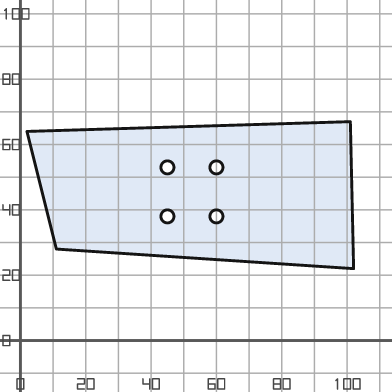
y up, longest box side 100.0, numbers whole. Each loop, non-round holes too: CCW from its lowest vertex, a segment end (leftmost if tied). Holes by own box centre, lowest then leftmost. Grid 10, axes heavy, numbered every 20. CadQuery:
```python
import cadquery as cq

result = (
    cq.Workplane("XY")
    .moveTo(102.0, 22.0)
    .lineTo(101.0, 67.0)
    .lineTo(2.0, 64.0)
    .lineTo(11.0, 28.0)
    .close()
    .moveTo(45.0, 38.0)
    .circle(2.0)
    .moveTo(60.0, 38.0)
    .circle(2.0)
    .moveTo(45.0, 53.0)
    .circle(2.0)
    .moveTo(60.0, 53.0)
    .circle(2.0)
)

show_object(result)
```